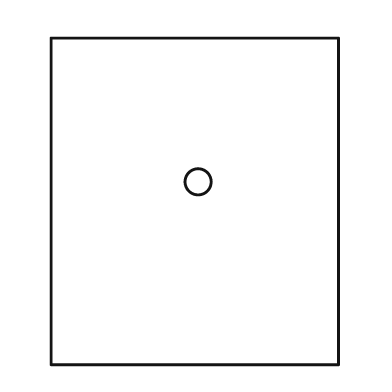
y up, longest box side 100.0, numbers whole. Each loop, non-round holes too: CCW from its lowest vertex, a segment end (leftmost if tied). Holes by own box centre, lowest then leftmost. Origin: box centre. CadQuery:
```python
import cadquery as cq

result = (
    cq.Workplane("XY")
    .moveTo(-44.0, -50.0)
    .lineTo(44.0, -50.0)
    .lineTo(44.0, 50.0)
    .lineTo(-44.0, 50.0)
    .close()
    .moveTo(1.0, 6.0)
    .circle(4.0)
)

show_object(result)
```